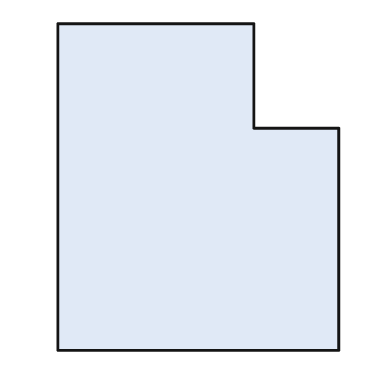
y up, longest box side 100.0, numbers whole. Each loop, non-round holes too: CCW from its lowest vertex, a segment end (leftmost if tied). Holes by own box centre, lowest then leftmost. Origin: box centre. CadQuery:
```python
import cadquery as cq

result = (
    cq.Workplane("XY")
    .moveTo(-43.0, -50.0)
    .lineTo(43.0, -50.0)
    .lineTo(43.0, 18.0)
    .lineTo(17.0, 18.0)
    .lineTo(17.0, 50.0)
    .lineTo(-43.0, 50.0)
    .close()
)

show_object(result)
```